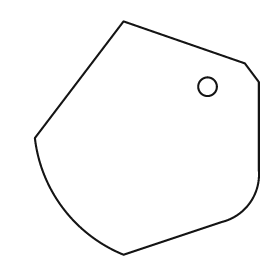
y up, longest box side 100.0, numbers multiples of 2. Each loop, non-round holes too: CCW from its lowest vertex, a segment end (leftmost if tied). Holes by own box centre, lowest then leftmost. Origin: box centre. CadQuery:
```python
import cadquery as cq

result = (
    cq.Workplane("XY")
    .moveTo(-10.0, -50.0)
    .lineTo(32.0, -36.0)
    .threePointArc((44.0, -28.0), (48.0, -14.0))
    .lineTo(48.0, 24.0)
    .lineTo(42.0, 32.0)
    .lineTo(-10.0, 50.0)
    .lineTo(-48.0, 0.0)
    .threePointArc((-36.0, -30.0), (-10.0, -50.0))
    .close()
    .moveTo(26.0, 22.0)
    .circle(4.0)
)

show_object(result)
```